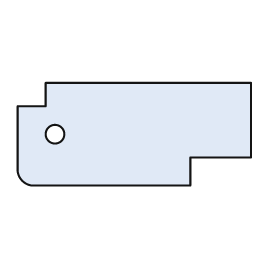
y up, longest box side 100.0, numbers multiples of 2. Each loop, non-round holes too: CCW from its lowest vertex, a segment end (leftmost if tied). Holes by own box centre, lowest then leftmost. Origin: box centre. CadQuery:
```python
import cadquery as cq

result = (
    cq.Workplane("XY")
    .moveTo(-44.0, -22.0)
    .lineTo(24.0, -22.0)
    .lineTo(24.0, -10.0)
    .lineTo(50.0, -10.0)
    .lineTo(50.0, 22.0)
    .lineTo(-38.0, 22.0)
    .lineTo(-38.0, 12.0)
    .lineTo(-50.0, 12.0)
    .lineTo(-50.0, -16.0)
    .threePointArc((-48.0, -20.0), (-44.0, -22.0))
    .close()
    .moveTo(-34.0, 0.0)
    .circle(4.0)
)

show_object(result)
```